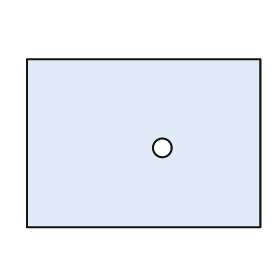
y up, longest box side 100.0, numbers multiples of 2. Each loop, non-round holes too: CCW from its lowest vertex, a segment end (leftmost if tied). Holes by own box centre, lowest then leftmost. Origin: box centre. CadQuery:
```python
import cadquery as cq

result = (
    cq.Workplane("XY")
    .moveTo(-50.0, -36.0)
    .lineTo(50.0, -36.0)
    .lineTo(50.0, 36.0)
    .lineTo(-50.0, 36.0)
    .close()
    .moveTo(8.0, -2.0)
    .circle(4.0)
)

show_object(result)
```